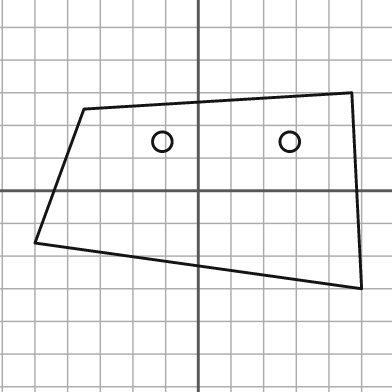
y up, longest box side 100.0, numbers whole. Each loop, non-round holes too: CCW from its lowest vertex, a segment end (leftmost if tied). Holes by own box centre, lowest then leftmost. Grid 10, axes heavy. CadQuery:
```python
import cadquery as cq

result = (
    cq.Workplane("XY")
    .moveTo(50.0, -30.0)
    .lineTo(47.0, 30.0)
    .lineTo(-35.0, 25.0)
    .lineTo(-50.0, -16.0)
    .close()
    .moveTo(-11.0, 15.0)
    .circle(3.0)
    .moveTo(28.0, 15.0)
    .circle(3.0)
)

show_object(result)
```